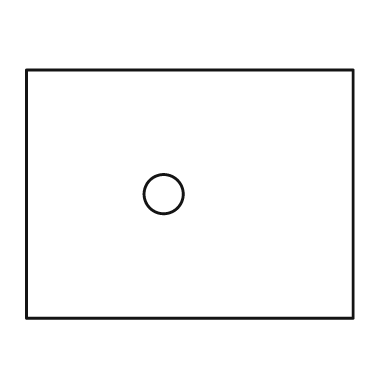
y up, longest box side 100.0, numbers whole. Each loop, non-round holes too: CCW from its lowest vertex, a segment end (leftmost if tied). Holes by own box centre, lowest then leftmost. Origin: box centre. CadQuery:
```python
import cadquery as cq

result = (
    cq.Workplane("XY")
    .moveTo(-50.0, -38.0)
    .lineTo(50.0, -38.0)
    .lineTo(50.0, 38.0)
    .lineTo(-50.0, 38.0)
    .close()
    .moveTo(-8.0, 0.0)
    .circle(6.0)
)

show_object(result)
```